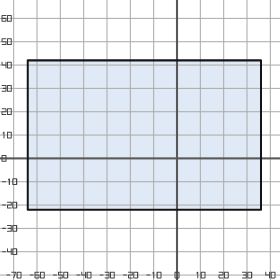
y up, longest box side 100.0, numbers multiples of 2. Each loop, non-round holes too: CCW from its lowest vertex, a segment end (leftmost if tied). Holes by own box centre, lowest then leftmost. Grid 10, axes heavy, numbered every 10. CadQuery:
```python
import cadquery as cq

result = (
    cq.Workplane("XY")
    .moveTo(-64.0, -22.0)
    .lineTo(36.0, -22.0)
    .lineTo(36.0, 42.0)
    .lineTo(-64.0, 42.0)
    .close()
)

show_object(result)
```